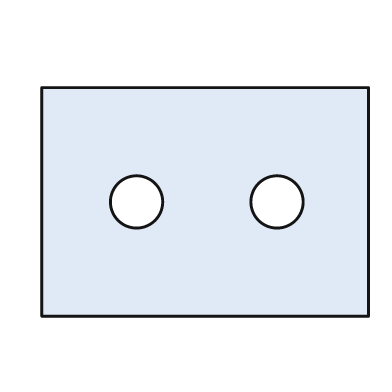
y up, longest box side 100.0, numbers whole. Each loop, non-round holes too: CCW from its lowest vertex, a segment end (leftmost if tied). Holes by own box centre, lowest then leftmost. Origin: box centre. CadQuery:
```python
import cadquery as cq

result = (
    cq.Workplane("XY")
    .moveTo(-50.0, -35.0)
    .lineTo(50.0, -35.0)
    .lineTo(50.0, 35.0)
    .lineTo(-50.0, 35.0)
    .close()
    .moveTo(-21.0, 0.0)
    .circle(8.0)
    .moveTo(22.0, 0.0)
    .circle(8.0)
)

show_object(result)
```